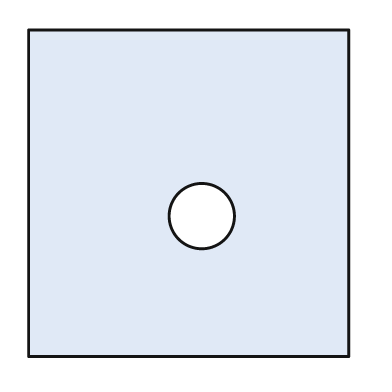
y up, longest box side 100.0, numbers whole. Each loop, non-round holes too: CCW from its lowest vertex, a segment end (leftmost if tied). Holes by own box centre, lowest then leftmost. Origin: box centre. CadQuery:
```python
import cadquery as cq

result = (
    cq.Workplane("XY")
    .moveTo(-49.0, -50.0)
    .lineTo(49.0, -50.0)
    .lineTo(49.0, 50.0)
    .lineTo(-49.0, 50.0)
    .close()
    .moveTo(4.0, -7.0)
    .circle(10.0)
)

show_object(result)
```